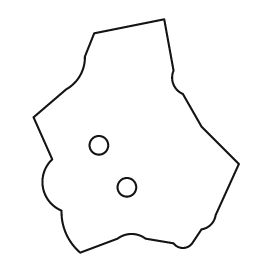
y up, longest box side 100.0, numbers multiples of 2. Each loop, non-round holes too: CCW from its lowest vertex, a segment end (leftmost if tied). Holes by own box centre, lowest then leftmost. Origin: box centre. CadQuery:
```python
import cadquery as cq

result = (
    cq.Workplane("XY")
    .moveTo(-24.0, -50.0)
    .lineTo(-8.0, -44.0)
    .threePointArc((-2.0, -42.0), (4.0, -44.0))
    .lineTo(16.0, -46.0)
    .threePointArc((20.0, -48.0), (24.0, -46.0))
    .lineTo(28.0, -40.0)
    .threePointArc((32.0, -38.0), (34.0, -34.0))
    .lineTo(44.0, -12.0)
    .lineTo(28.0, 4.0)
    .lineTo(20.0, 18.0)
    .threePointArc((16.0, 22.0), (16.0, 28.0))
    .lineTo(12.0, 50.0)
    .lineTo(-18.0, 44.0)
    .lineTo(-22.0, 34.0)
    .threePointArc((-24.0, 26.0), (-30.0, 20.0))
    .lineTo(-44.0, 8.0)
    .lineTo(-36.0, -10.0)
    .threePointArc((-40.0, -22.0), (-32.0, -32.0))
    .threePointArc((-30.0, -42.0), (-24.0, -50.0))
    .close()
    .moveTo(-4.0, -22.0)
    .circle(4.0)
    .moveTo(-16.0, -4.0)
    .circle(4.0)
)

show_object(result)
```